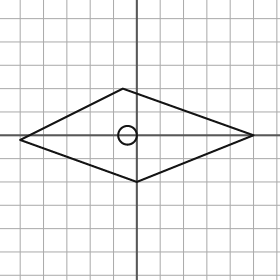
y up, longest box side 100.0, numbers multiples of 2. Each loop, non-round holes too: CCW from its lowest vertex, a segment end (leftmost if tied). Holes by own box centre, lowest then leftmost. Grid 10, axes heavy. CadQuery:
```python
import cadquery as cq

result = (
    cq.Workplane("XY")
    .moveTo(0.0, -20.0)
    .lineTo(50.0, 0.0)
    .lineTo(-6.0, 20.0)
    .lineTo(-50.0, -2.0)
    .close()
    .moveTo(-4.0, 0.0)
    .circle(4.0)
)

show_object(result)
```